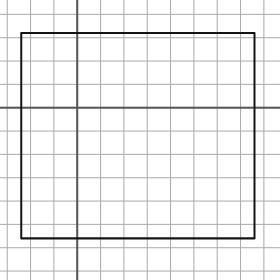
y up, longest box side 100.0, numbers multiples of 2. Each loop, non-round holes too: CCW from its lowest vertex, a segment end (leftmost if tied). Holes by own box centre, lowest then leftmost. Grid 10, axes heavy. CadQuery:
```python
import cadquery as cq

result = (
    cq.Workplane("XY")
    .moveTo(-24.0, -56.0)
    .lineTo(76.0, -56.0)
    .lineTo(76.0, 32.0)
    .lineTo(-24.0, 32.0)
    .close()
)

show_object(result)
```